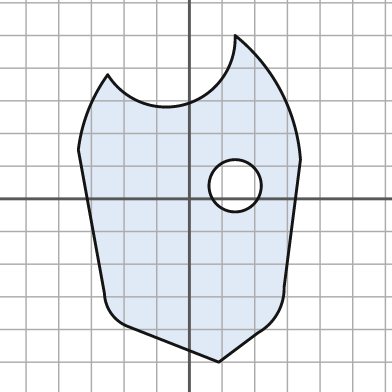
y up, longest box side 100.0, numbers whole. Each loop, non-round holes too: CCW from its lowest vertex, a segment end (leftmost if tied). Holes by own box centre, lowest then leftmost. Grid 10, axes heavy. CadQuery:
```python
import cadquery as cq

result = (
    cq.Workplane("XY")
    .moveTo(9.0, -50.0)
    .lineTo(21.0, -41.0)
    .threePointArc((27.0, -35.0), (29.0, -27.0))
    .lineTo(34.0, 12.0)
    .threePointArc((28.0, 33.0), (14.0, 50.0))
    .threePointArc((-1.0, 29.0), (-25.0, 38.0))
    .threePointArc((-31.0, 27.0), (-34.0, 15.0))
    .lineTo(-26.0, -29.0)
    .threePointArc((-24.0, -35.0), (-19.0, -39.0))
    .close()
    .moveTo(14.0, 4.0)
    .circle(8.0)
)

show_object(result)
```